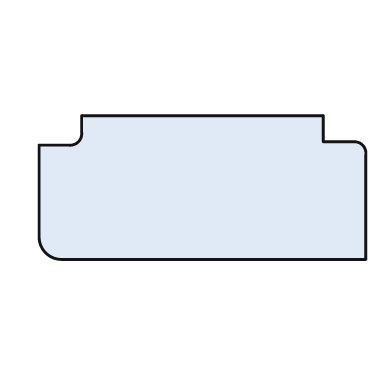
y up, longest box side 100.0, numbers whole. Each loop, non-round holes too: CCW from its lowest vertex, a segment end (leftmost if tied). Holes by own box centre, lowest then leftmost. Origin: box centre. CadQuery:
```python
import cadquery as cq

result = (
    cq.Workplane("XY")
    .moveTo(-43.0, -22.0)
    .lineTo(50.0, -22.0)
    .lineTo(50.0, 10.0)
    .threePointArc((49.0, 13.0), (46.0, 14.0))
    .lineTo(37.0, 14.0)
    .lineTo(37.0, 22.0)
    .lineTo(-37.0, 22.0)
    .lineTo(-37.0, 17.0)
    .threePointArc((-38.0, 14.0), (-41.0, 13.0))
    .lineTo(-50.0, 13.0)
    .lineTo(-50.0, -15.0)
    .threePointArc((-48.0, -20.0), (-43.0, -22.0))
    .close()
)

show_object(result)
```